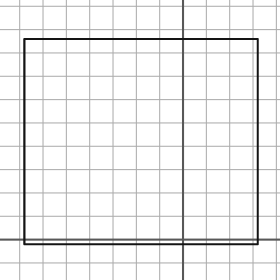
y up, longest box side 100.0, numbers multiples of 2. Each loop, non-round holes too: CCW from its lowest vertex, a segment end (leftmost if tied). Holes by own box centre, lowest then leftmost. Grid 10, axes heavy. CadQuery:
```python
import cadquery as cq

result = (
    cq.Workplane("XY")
    .moveTo(-68.0, -2.0)
    .lineTo(32.0, -2.0)
    .lineTo(32.0, 86.0)
    .lineTo(-68.0, 86.0)
    .close()
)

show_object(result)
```